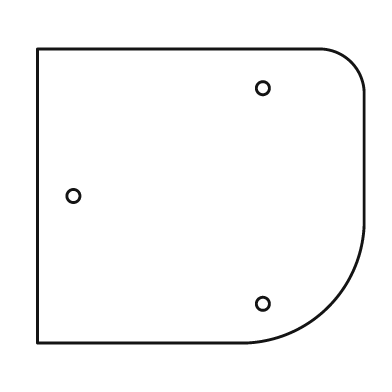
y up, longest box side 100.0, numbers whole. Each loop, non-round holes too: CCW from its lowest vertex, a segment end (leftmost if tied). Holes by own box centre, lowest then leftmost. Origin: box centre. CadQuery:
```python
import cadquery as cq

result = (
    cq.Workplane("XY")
    .moveTo(-50.0, -45.0)
    .lineTo(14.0, -45.0)
    .threePointArc((39.0, -34.0), (50.0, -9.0))
    .lineTo(50.0, 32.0)
    .threePointArc((46.0, 41.0), (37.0, 45.0))
    .lineTo(-50.0, 45.0)
    .close()
    .moveTo(19.0, -33.0)
    .circle(2.0)
    .moveTo(-39.0, 0.0)
    .circle(2.0)
    .moveTo(19.0, 33.0)
    .circle(2.0)
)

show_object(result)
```